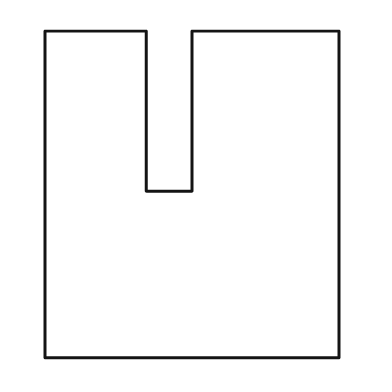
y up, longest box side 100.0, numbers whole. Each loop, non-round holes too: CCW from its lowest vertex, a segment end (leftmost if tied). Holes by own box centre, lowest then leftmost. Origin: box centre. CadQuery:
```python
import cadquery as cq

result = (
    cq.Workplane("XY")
    .moveTo(-45.0, -50.0)
    .lineTo(45.0, -50.0)
    .lineTo(45.0, 50.0)
    .lineTo(0.0, 50.0)
    .lineTo(0.0, 1.0)
    .lineTo(-14.0, 1.0)
    .lineTo(-14.0, 50.0)
    .lineTo(-45.0, 50.0)
    .close()
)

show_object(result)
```